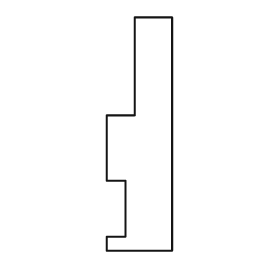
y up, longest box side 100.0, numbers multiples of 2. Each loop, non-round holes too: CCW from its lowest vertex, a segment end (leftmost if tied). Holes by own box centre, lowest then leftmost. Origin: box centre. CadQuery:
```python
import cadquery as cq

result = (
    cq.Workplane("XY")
    .moveTo(-14.0, -50.0)
    .lineTo(14.0, -50.0)
    .lineTo(14.0, 50.0)
    .lineTo(-2.0, 50.0)
    .lineTo(-2.0, 8.0)
    .lineTo(-14.0, 8.0)
    .lineTo(-14.0, -20.0)
    .lineTo(-6.0, -20.0)
    .lineTo(-6.0, -44.0)
    .lineTo(-14.0, -44.0)
    .close()
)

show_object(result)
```